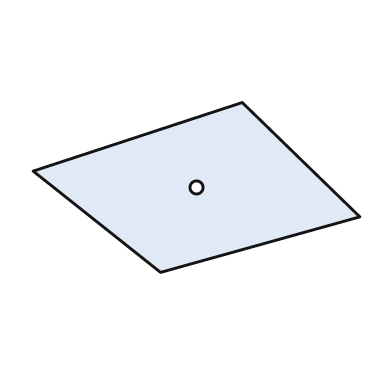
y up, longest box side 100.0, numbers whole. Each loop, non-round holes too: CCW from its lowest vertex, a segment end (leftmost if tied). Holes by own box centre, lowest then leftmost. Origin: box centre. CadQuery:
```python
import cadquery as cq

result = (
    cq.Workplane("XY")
    .moveTo(-11.0, -26.0)
    .lineTo(50.0, -9.0)
    .lineTo(14.0, 26.0)
    .lineTo(-50.0, 5.0)
    .close()
    .moveTo(0.0, 0.0)
    .circle(2.0)
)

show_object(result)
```